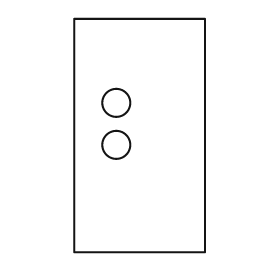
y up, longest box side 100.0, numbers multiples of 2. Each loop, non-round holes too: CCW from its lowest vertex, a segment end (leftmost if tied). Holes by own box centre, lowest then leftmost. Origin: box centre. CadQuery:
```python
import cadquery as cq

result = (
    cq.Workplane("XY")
    .moveTo(-28.0, -50.0)
    .lineTo(28.0, -50.0)
    .lineTo(28.0, 50.0)
    .lineTo(-28.0, 50.0)
    .close()
    .moveTo(-10.0, -4.0)
    .circle(6.0)
    .moveTo(-10.0, 14.0)
    .circle(6.0)
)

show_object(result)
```